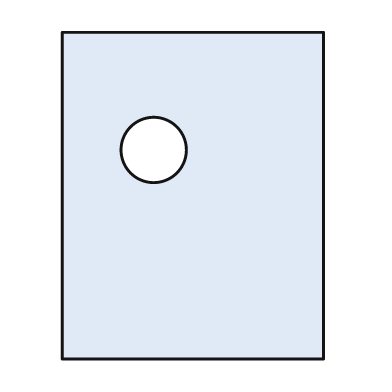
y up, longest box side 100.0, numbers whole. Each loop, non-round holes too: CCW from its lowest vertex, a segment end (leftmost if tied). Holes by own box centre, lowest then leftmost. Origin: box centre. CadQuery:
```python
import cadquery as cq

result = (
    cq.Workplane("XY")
    .moveTo(-40.0, -50.0)
    .lineTo(40.0, -50.0)
    .lineTo(40.0, 50.0)
    .lineTo(-40.0, 50.0)
    .close()
    .moveTo(-12.0, 14.0)
    .circle(10.0)
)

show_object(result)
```